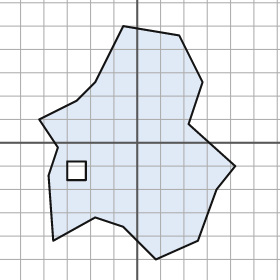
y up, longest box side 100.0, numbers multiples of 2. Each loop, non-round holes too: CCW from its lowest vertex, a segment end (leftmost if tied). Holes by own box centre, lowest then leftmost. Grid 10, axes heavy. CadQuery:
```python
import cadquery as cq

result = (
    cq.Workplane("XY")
    .moveTo(8.0, -50.0)
    .lineTo(26.0, -42.0)
    .lineTo(34.0, -20.0)
    .lineTo(42.0, -10.0)
    .lineTo(22.0, 8.0)
    .lineTo(28.0, 26.0)
    .lineTo(18.0, 46.0)
    .lineTo(-6.0, 50.0)
    .lineTo(-18.0, 26.0)
    .lineTo(-26.0, 18.0)
    .lineTo(-42.0, 10.0)
    .lineTo(-34.0, -2.0)
    .lineTo(-38.0, -14.0)
    .lineTo(-36.0, -42.0)
    .lineTo(-18.0, -32.0)
    .lineTo(-6.0, -36.0)
    .close()
    .moveTo(-30.0, -16.0)
    .lineTo(-22.0, -16.0)
    .lineTo(-22.0, -8.0)
    .lineTo(-30.0, -8.0)
    .close()
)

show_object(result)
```